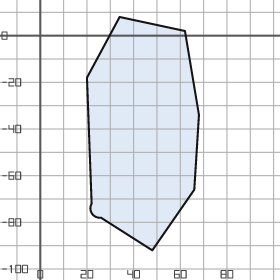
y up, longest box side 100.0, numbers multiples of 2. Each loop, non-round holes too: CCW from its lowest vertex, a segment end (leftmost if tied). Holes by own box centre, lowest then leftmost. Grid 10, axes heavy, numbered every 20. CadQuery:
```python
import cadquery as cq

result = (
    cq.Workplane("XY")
    .moveTo(48.0, -92.0)
    .lineTo(66.0, -66.0)
    .lineTo(68.0, -34.0)
    .lineTo(62.0, 2.0)
    .lineTo(34.0, 8.0)
    .lineTo(20.0, -18.0)
    .lineTo(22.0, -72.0)
    .threePointArc((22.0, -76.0), (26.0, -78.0))
    .close()
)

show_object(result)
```